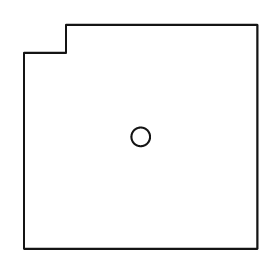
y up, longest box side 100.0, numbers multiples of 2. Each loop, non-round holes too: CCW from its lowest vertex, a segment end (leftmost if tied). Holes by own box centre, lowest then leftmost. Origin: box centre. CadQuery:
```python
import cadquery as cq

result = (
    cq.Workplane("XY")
    .moveTo(-50.0, -48.0)
    .lineTo(50.0, -48.0)
    .lineTo(50.0, 48.0)
    .lineTo(-32.0, 48.0)
    .lineTo(-32.0, 36.0)
    .lineTo(-50.0, 36.0)
    .close()
    .moveTo(0.0, 0.0)
    .circle(4.0)
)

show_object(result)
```